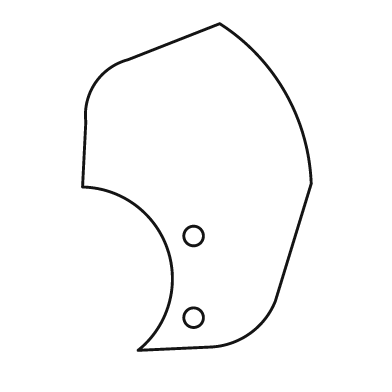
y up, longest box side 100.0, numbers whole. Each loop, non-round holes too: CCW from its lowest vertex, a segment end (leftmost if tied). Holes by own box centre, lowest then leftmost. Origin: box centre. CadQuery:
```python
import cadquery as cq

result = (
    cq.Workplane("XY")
    .moveTo(-18.0, -50.0)
    .lineTo(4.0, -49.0)
    .threePointArc((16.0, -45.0), (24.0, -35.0))
    .lineTo(35.0, 1.0)
    .threePointArc((27.0, 29.0), (7.0, 50.0))
    .lineTo(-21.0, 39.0)
    .threePointArc((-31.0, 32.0), (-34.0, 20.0))
    .lineTo(-35.0, 0.0)
    .threePointArc((-9.0, -19.0), (-18.0, -50.0))
    .close()
    .moveTo(-1.0, -40.0)
    .circle(3.0)
    .moveTo(-1.0, -15.0)
    .circle(3.0)
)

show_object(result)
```